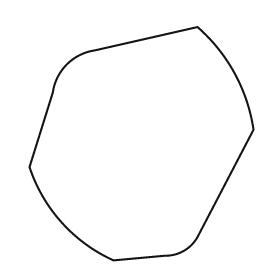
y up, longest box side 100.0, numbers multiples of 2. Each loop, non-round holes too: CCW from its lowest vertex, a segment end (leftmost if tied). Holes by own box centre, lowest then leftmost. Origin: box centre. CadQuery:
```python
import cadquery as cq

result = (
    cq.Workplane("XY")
    .moveTo(-12.0, -50.0)
    .lineTo(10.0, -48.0)
    .threePointArc((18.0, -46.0), (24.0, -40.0))
    .lineTo(48.0, 6.0)
    .threePointArc((40.0, 30.0), (24.0, 50.0))
    .lineTo(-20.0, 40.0)
    .threePointArc((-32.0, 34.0), (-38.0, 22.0))
    .lineTo(-48.0, -10.0)
    .threePointArc((-34.0, -34.0), (-12.0, -50.0))
    .close()
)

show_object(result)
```